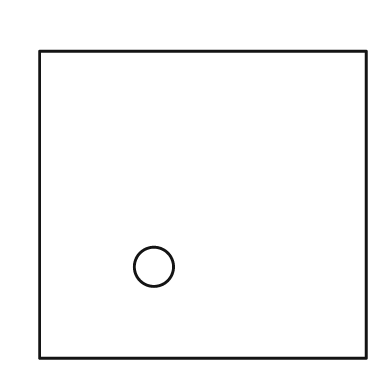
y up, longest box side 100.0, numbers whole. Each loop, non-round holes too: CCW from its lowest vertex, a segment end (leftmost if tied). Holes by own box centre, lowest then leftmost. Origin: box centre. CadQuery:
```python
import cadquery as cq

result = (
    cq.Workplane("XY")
    .moveTo(-50.0, -47.0)
    .lineTo(50.0, -47.0)
    .lineTo(50.0, 47.0)
    .lineTo(-50.0, 47.0)
    .close()
    .moveTo(-15.0, -19.0)
    .circle(6.0)
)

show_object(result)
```